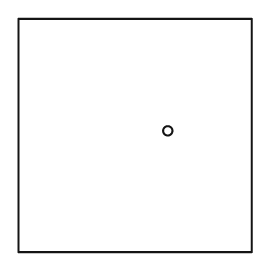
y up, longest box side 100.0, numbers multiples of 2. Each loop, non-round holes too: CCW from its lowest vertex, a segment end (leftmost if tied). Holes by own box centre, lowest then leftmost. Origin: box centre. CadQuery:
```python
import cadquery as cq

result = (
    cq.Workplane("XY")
    .moveTo(-50.0, -50.0)
    .lineTo(50.0, -50.0)
    .lineTo(50.0, 50.0)
    .lineTo(-50.0, 50.0)
    .close()
    .moveTo(14.0, 2.0)
    .circle(2.0)
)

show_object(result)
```